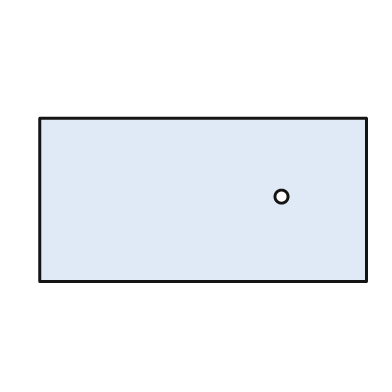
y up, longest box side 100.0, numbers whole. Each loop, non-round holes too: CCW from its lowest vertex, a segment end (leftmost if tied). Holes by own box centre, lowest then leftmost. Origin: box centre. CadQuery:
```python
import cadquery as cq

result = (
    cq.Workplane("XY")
    .moveTo(-50.0, -25.0)
    .lineTo(50.0, -25.0)
    .lineTo(50.0, 25.0)
    .lineTo(-50.0, 25.0)
    .close()
    .moveTo(24.0, 1.0)
    .circle(2.0)
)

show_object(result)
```